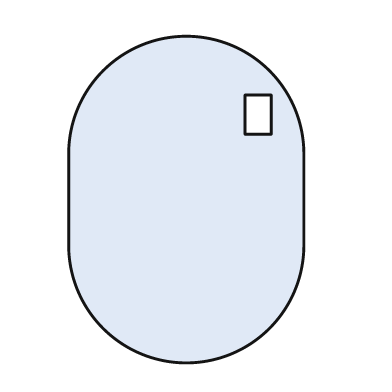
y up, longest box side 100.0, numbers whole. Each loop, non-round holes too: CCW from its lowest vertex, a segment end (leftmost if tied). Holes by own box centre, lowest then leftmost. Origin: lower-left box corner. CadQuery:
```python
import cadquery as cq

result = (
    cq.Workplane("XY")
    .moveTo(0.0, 36.0)
    .threePointArc((36.0, 0.0), (72.0, 36.0))
    .lineTo(72.0, 64.0)
    .threePointArc((36.0, 100.0), (0.0, 64.0))
    .close()
    .moveTo(54.0, 70.0)
    .lineTo(62.0, 70.0)
    .lineTo(62.0, 82.0)
    .lineTo(54.0, 82.0)
    .close()
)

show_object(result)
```